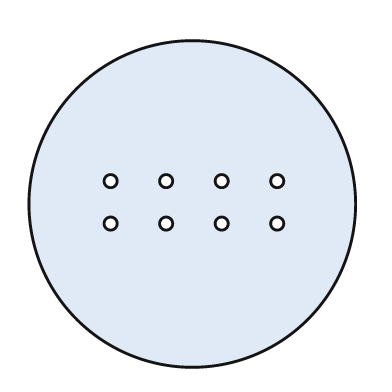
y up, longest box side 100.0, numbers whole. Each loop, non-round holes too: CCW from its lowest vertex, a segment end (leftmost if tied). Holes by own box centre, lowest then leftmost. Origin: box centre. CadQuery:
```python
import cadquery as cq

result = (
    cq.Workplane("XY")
    .moveTo(0.0, 0.0)
    .circle(50.0)
    .moveTo(-25.0, -6.0)
    .circle(2.0)
    .moveTo(-8.0, -6.0)
    .circle(2.0)
    .moveTo(9.0, -6.0)
    .circle(2.0)
    .moveTo(26.0, -6.0)
    .circle(2.0)
    .moveTo(-25.0, 7.0)
    .circle(2.0)
    .moveTo(-8.0, 7.0)
    .circle(2.0)
    .moveTo(9.0, 7.0)
    .circle(2.0)
    .moveTo(26.0, 7.0)
    .circle(2.0)
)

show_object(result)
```